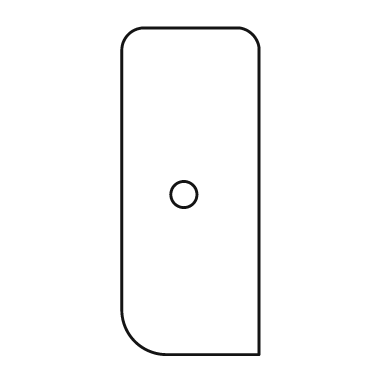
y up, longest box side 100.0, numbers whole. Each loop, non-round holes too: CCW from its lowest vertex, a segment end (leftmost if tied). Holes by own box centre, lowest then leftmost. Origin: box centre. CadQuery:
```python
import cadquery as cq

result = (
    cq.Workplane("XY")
    .moveTo(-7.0, -50.0)
    .lineTo(21.0, -50.0)
    .lineTo(21.0, 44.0)
    .threePointArc((19.0, 48.0), (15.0, 50.0))
    .lineTo(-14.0, 50.0)
    .threePointArc((-19.0, 48.0), (-21.0, 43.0))
    .lineTo(-21.0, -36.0)
    .threePointArc((-17.0, -46.0), (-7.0, -50.0))
    .close()
    .moveTo(-2.0, -1.0)
    .circle(4.0)
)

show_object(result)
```